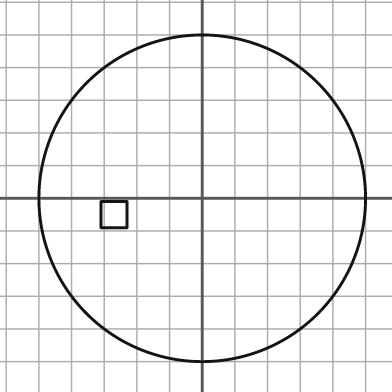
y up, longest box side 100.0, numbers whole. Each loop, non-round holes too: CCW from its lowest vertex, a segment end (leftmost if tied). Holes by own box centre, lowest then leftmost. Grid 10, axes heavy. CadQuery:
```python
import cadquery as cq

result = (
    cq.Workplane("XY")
    .moveTo(0.0, 0.0)
    .circle(50.0)
    .moveTo(-31.0, -9.0)
    .lineTo(-23.0, -9.0)
    .lineTo(-23.0, -1.0)
    .lineTo(-31.0, -1.0)
    .close()
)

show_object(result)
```